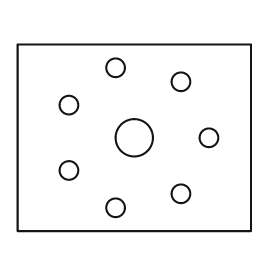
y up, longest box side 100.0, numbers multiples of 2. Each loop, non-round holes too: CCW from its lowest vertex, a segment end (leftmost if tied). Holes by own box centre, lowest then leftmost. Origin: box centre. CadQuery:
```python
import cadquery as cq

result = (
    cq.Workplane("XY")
    .moveTo(-50.0, -40.0)
    .lineTo(50.0, -40.0)
    .lineTo(50.0, 40.0)
    .lineTo(-50.0, 40.0)
    .close()
    .moveTo(-8.0, -30.0)
    .circle(4.0)
    .moveTo(20.0, -24.0)
    .circle(4.0)
    .moveTo(-28.0, -14.0)
    .circle(4.0)
    .moveTo(0.0, 0.0)
    .circle(8.0)
    .moveTo(32.0, 0.0)
    .circle(4.0)
    .moveTo(-28.0, 14.0)
    .circle(4.0)
    .moveTo(20.0, 24.0)
    .circle(4.0)
    .moveTo(-8.0, 30.0)
    .circle(4.0)
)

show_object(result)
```